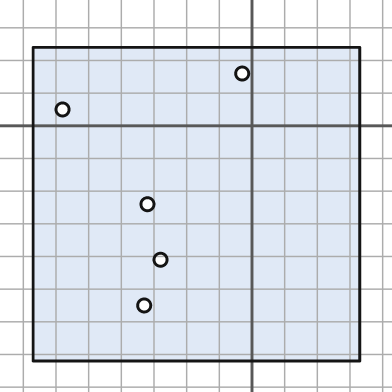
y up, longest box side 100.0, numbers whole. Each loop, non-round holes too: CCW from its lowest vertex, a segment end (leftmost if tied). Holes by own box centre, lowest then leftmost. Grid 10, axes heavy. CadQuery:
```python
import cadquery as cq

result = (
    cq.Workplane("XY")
    .moveTo(-67.0, -72.0)
    .lineTo(33.0, -72.0)
    .lineTo(33.0, 24.0)
    .lineTo(-67.0, 24.0)
    .close()
    .moveTo(-33.0, -55.0)
    .circle(2.0)
    .moveTo(-28.0, -41.0)
    .circle(2.0)
    .moveTo(-32.0, -24.0)
    .circle(2.0)
    .moveTo(-58.0, 5.0)
    .circle(2.0)
    .moveTo(-3.0, 16.0)
    .circle(2.0)
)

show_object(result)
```